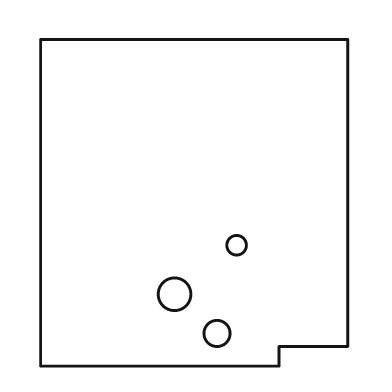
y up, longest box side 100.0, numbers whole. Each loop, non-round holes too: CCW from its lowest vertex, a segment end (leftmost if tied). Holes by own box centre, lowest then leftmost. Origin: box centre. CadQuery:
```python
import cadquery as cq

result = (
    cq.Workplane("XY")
    .moveTo(-47.0, -50.0)
    .lineTo(26.0, -50.0)
    .lineTo(26.0, -44.0)
    .lineTo(47.0, -44.0)
    .lineTo(47.0, 50.0)
    .lineTo(-47.0, 50.0)
    .close()
    .moveTo(7.0, -40.0)
    .circle(4.0)
    .moveTo(-6.0, -28.0)
    .circle(5.0)
    .moveTo(13.0, -13.0)
    .circle(3.0)
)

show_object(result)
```